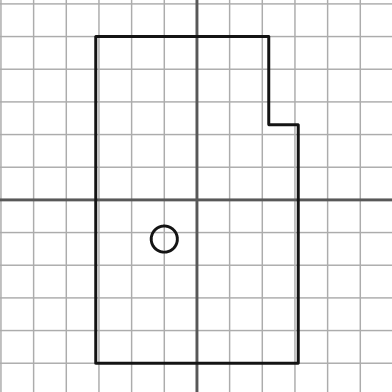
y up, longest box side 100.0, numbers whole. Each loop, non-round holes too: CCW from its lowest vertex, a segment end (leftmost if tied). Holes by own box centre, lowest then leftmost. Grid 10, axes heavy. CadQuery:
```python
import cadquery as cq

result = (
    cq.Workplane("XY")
    .moveTo(-31.0, -50.0)
    .lineTo(31.0, -50.0)
    .lineTo(31.0, 23.0)
    .lineTo(22.0, 23.0)
    .lineTo(22.0, 50.0)
    .lineTo(-31.0, 50.0)
    .close()
    .moveTo(-10.0, -12.0)
    .circle(4.0)
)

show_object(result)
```